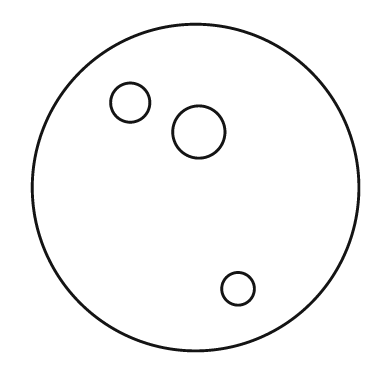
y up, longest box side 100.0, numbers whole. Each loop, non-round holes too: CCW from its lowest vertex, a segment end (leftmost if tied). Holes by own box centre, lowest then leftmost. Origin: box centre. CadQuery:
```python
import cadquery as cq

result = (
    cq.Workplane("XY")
    .moveTo(0.0, 0.0)
    .circle(50.0)
    .moveTo(13.0, -31.0)
    .circle(5.0)
    .moveTo(1.0, 17.0)
    .circle(8.0)
    .moveTo(-20.0, 26.0)
    .circle(6.0)
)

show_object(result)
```